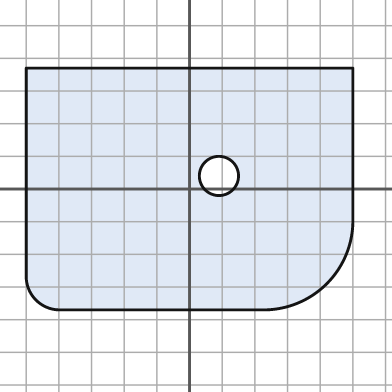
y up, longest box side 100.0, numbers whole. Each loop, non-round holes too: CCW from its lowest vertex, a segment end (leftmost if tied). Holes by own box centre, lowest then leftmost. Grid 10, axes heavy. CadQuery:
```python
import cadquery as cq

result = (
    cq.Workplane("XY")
    .moveTo(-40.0, -37.0)
    .lineTo(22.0, -37.0)
    .threePointArc((42.0, -29.0), (50.0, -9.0))
    .lineTo(50.0, 37.0)
    .lineTo(-50.0, 37.0)
    .lineTo(-50.0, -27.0)
    .threePointArc((-47.0, -34.0), (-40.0, -37.0))
    .close()
    .moveTo(9.0, 4.0)
    .circle(6.0)
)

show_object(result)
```